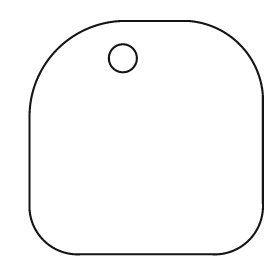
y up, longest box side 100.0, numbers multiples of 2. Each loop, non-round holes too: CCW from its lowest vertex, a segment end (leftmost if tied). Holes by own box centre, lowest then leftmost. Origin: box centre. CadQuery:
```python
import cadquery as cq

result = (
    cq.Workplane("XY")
    .moveTo(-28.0, -50.0)
    .lineTo(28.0, -50.0)
    .threePointArc((44.0, -44.0), (50.0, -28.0))
    .lineTo(50.0, 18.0)
    .threePointArc((40.0, 40.0), (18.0, 50.0))
    .lineTo(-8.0, 50.0)
    .threePointArc((-38.0, 38.0), (-50.0, 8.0))
    .lineTo(-50.0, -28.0)
    .threePointArc((-44.0, -44.0), (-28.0, -50.0))
    .close()
    .moveTo(-10.0, 34.0)
    .circle(6.0)
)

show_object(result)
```